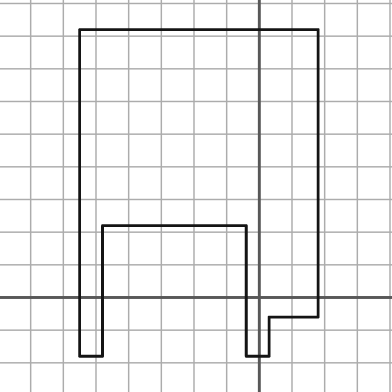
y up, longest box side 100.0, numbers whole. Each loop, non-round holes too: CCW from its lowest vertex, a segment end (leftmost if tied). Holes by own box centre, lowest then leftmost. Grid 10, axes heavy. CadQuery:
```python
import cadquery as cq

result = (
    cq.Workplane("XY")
    .moveTo(-55.0, -18.0)
    .lineTo(-48.0, -18.0)
    .lineTo(-48.0, 22.0)
    .lineTo(-4.0, 22.0)
    .lineTo(-4.0, -18.0)
    .lineTo(3.0, -18.0)
    .lineTo(3.0, -6.0)
    .lineTo(18.0, -6.0)
    .lineTo(18.0, 82.0)
    .lineTo(-55.0, 82.0)
    .close()
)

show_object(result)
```